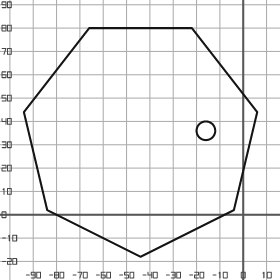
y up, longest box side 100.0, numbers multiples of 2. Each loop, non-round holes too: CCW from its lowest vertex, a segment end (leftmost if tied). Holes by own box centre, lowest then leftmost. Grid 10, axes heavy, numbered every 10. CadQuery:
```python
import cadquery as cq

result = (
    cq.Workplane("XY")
    .moveTo(-44.0, -18.0)
    .lineTo(-4.0, 2.0)
    .lineTo(6.0, 44.0)
    .lineTo(-22.0, 80.0)
    .lineTo(-66.0, 80.0)
    .lineTo(-94.0, 44.0)
    .lineTo(-84.0, 2.0)
    .close()
    .moveTo(-16.0, 36.0)
    .circle(4.0)
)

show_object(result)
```